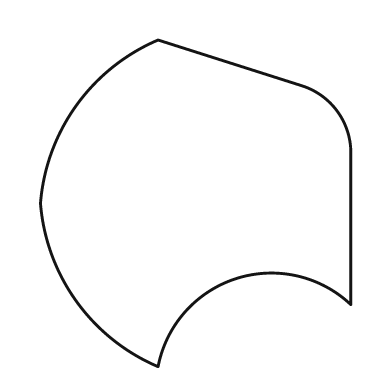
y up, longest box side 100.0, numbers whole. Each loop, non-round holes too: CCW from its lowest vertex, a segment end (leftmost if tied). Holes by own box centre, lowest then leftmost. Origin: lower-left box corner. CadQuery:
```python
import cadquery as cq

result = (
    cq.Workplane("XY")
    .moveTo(36.0, 0.0)
    .threePointArc((60.0, 27.0), (95.0, 19.0))
    .lineTo(95.0, 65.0)
    .threePointArc((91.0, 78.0), (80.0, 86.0))
    .lineTo(36.0, 100.0)
    .threePointArc((11.0, 80.0), (0.0, 50.0))
    .threePointArc((11.0, 20.0), (36.0, 0.0))
    .close()
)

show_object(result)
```